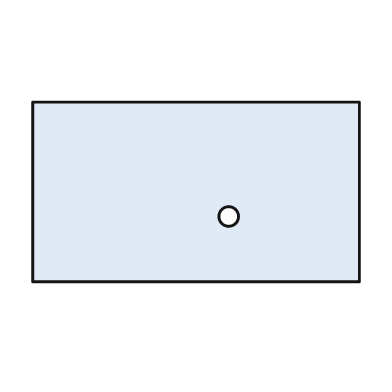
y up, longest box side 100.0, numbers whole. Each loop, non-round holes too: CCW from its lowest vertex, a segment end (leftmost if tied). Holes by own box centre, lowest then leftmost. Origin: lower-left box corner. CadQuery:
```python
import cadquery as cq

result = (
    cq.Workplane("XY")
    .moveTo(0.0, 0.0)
    .lineTo(100.0, 0.0)
    .lineTo(100.0, 55.0)
    .lineTo(0.0, 55.0)
    .close()
    .moveTo(60.0, 20.0)
    .circle(3.0)
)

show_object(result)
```